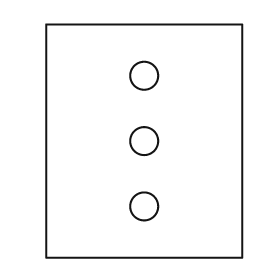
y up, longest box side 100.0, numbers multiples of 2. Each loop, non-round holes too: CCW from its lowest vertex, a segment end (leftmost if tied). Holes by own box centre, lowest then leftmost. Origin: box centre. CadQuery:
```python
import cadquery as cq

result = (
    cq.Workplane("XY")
    .moveTo(-42.0, -50.0)
    .lineTo(42.0, -50.0)
    .lineTo(42.0, 50.0)
    .lineTo(-42.0, 50.0)
    .close()
    .moveTo(0.0, -28.0)
    .circle(6.0)
    .moveTo(0.0, 0.0)
    .circle(6.0)
    .moveTo(0.0, 28.0)
    .circle(6.0)
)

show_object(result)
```